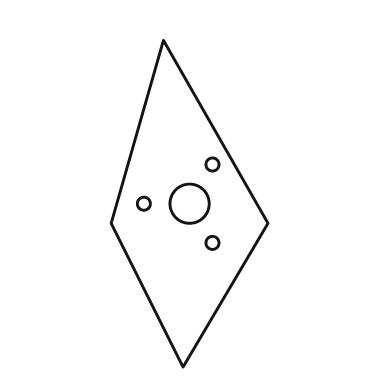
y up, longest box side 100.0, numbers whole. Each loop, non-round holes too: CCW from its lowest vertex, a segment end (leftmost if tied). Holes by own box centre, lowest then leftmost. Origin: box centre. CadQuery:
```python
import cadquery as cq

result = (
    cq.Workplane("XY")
    .moveTo(-2.0, -50.0)
    .lineTo(24.0, -6.0)
    .lineTo(-8.0, 50.0)
    .lineTo(-24.0, -6.0)
    .close()
    .moveTo(7.0, -12.0)
    .circle(2.0)
    .moveTo(-14.0, 0.0)
    .circle(2.0)
    .moveTo(0.0, 0.0)
    .circle(6.0)
    .moveTo(7.0, 12.0)
    .circle(2.0)
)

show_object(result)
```